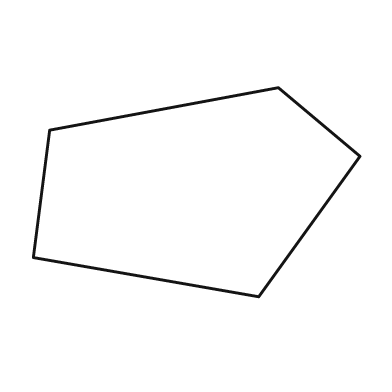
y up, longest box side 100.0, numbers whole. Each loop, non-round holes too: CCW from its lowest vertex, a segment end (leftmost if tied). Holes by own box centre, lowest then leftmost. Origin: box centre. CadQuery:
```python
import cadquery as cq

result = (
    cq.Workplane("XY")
    .moveTo(19.0, -32.0)
    .lineTo(50.0, 11.0)
    .lineTo(25.0, 32.0)
    .lineTo(-45.0, 19.0)
    .lineTo(-50.0, -20.0)
    .close()
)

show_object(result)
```